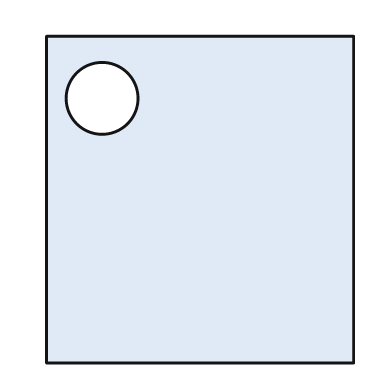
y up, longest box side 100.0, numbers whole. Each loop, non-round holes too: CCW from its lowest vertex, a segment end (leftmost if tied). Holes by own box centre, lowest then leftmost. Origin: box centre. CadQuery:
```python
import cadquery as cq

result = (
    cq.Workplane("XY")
    .moveTo(-47.0, -50.0)
    .lineTo(47.0, -50.0)
    .lineTo(47.0, 50.0)
    .lineTo(-47.0, 50.0)
    .close()
    .moveTo(-30.0, 31.0)
    .circle(11.0)
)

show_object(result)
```